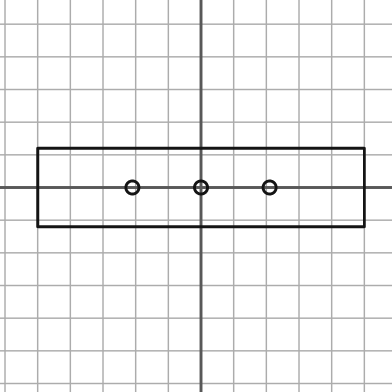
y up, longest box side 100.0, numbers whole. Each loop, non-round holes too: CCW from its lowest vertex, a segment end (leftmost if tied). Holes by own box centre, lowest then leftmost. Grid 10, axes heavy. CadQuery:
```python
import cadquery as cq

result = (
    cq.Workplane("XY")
    .moveTo(-50.0, -12.0)
    .lineTo(50.0, -12.0)
    .lineTo(50.0, 12.0)
    .lineTo(-50.0, 12.0)
    .close()
    .moveTo(-21.0, 0.0)
    .circle(2.0)
    .moveTo(0.0, 0.0)
    .circle(2.0)
    .moveTo(21.0, 0.0)
    .circle(2.0)
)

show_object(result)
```